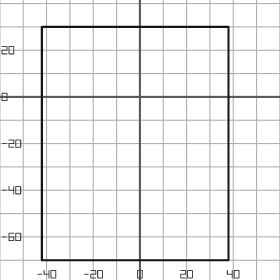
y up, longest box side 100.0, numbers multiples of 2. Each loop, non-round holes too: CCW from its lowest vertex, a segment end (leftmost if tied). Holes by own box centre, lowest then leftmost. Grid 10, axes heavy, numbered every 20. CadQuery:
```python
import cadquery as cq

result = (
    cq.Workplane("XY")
    .moveTo(-42.0, -70.0)
    .lineTo(38.0, -70.0)
    .lineTo(38.0, 30.0)
    .lineTo(-42.0, 30.0)
    .close()
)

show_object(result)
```